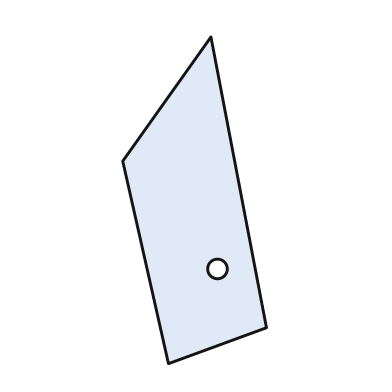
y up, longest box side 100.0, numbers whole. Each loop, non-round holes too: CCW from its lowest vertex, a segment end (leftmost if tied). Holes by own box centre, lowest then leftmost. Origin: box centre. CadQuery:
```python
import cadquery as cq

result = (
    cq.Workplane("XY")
    .moveTo(-8.0, -50.0)
    .lineTo(22.0, -39.0)
    .lineTo(5.0, 50.0)
    .lineTo(-22.0, 12.0)
    .close()
    .moveTo(7.0, -21.0)
    .circle(3.0)
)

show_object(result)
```